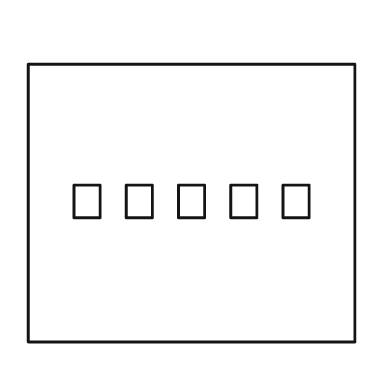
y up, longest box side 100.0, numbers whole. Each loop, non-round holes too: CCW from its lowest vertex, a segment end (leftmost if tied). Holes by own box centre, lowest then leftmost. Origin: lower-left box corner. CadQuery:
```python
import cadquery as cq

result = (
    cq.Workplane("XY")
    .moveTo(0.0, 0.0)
    .lineTo(100.0, 0.0)
    .lineTo(100.0, 85.0)
    .lineTo(0.0, 85.0)
    .close()
    .moveTo(14.0, 38.0)
    .lineTo(22.0, 38.0)
    .lineTo(22.0, 48.0)
    .lineTo(14.0, 48.0)
    .close()
    .moveTo(30.0, 38.0)
    .lineTo(38.0, 38.0)
    .lineTo(38.0, 48.0)
    .lineTo(30.0, 48.0)
    .close()
    .moveTo(46.0, 38.0)
    .lineTo(54.0, 38.0)
    .lineTo(54.0, 48.0)
    .lineTo(46.0, 48.0)
    .close()
    .moveTo(62.0, 38.0)
    .lineTo(70.0, 38.0)
    .lineTo(70.0, 48.0)
    .lineTo(62.0, 48.0)
    .close()
    .moveTo(78.0, 38.0)
    .lineTo(86.0, 38.0)
    .lineTo(86.0, 48.0)
    .lineTo(78.0, 48.0)
    .close()
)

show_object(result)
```